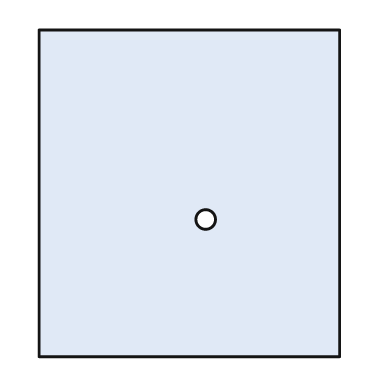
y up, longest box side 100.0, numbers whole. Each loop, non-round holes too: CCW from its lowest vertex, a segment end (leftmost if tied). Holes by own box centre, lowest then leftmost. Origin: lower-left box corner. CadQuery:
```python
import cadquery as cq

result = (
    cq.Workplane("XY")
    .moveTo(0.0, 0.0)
    .lineTo(92.0, 0.0)
    .lineTo(92.0, 100.0)
    .lineTo(0.0, 100.0)
    .close()
    .moveTo(51.0, 42.0)
    .circle(3.0)
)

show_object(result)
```